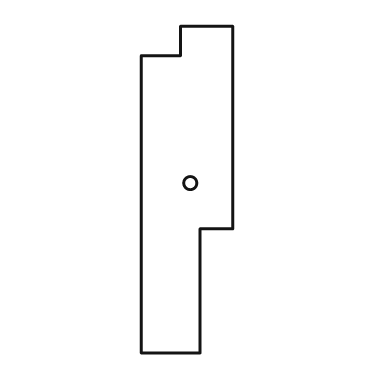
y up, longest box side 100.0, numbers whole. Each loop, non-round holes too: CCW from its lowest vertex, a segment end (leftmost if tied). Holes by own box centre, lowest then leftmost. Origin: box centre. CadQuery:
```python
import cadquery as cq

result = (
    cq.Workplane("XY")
    .moveTo(-14.0, -50.0)
    .lineTo(4.0, -50.0)
    .lineTo(4.0, -12.0)
    .lineTo(14.0, -12.0)
    .lineTo(14.0, 50.0)
    .lineTo(-2.0, 50.0)
    .lineTo(-2.0, 41.0)
    .lineTo(-14.0, 41.0)
    .close()
    .moveTo(1.0, 2.0)
    .circle(2.0)
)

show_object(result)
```